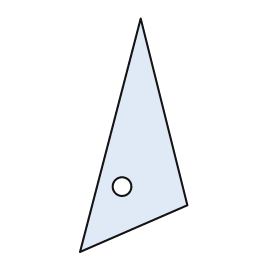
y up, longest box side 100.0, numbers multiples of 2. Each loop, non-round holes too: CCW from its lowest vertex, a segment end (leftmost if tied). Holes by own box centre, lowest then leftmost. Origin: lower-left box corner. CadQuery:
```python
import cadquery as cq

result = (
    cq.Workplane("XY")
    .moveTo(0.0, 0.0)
    .lineTo(46.0, 20.0)
    .lineTo(26.0, 100.0)
    .close()
    .moveTo(18.0, 28.0)
    .circle(4.0)
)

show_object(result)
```